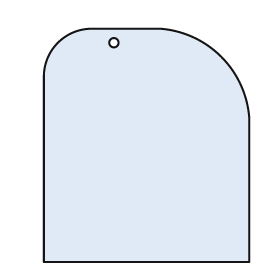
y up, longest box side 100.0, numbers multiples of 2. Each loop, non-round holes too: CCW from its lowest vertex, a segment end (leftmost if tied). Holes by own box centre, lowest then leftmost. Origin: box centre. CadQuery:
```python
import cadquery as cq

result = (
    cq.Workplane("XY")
    .moveTo(-44.0, -50.0)
    .lineTo(44.0, -50.0)
    .lineTo(44.0, 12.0)
    .threePointArc((32.0, 38.0), (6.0, 50.0))
    .lineTo(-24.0, 50.0)
    .threePointArc((-38.0, 44.0), (-44.0, 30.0))
    .close()
    .moveTo(-14.0, 44.0)
    .circle(2.0)
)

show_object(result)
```